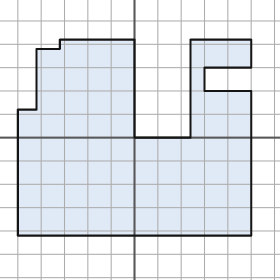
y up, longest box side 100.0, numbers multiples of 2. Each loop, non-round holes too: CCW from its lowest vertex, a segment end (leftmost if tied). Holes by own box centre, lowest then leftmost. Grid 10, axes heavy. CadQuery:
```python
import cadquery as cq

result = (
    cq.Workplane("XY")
    .moveTo(-50.0, -42.0)
    .lineTo(50.0, -42.0)
    .lineTo(50.0, 20.0)
    .lineTo(30.0, 20.0)
    .lineTo(30.0, 30.0)
    .lineTo(50.0, 30.0)
    .lineTo(50.0, 42.0)
    .lineTo(24.0, 42.0)
    .lineTo(24.0, 0.0)
    .lineTo(0.0, 0.0)
    .lineTo(0.0, 42.0)
    .lineTo(-32.0, 42.0)
    .lineTo(-32.0, 38.0)
    .lineTo(-42.0, 38.0)
    .lineTo(-42.0, 12.0)
    .lineTo(-50.0, 12.0)
    .close()
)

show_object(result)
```